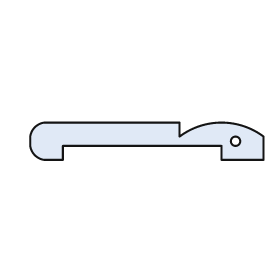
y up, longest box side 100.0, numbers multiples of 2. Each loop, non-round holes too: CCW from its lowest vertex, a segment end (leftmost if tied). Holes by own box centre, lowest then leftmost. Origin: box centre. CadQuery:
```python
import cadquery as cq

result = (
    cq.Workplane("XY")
    .moveTo(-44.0, -8.0)
    .lineTo(-36.0, -8.0)
    .lineTo(-36.0, -2.0)
    .lineTo(32.0, -2.0)
    .lineTo(32.0, -8.0)
    .lineTo(50.0, -8.0)
    .lineTo(50.0, 2.0)
    .threePointArc((32.0, 8.0), (14.0, 2.0))
    .lineTo(14.0, 8.0)
    .lineTo(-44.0, 8.0)
    .threePointArc((-48.0, 6.0), (-50.0, 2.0))
    .lineTo(-50.0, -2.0)
    .threePointArc((-48.0, -6.0), (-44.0, -8.0))
    .close()
    .moveTo(38.0, 0.0)
    .circle(2.0)
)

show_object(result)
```